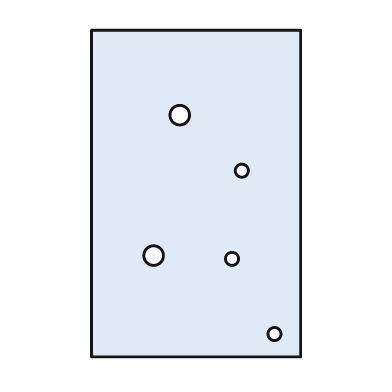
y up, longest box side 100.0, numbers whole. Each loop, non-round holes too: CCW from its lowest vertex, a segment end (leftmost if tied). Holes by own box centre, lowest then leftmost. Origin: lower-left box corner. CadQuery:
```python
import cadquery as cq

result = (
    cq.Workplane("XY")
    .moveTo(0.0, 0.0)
    .lineTo(64.0, 0.0)
    .lineTo(64.0, 100.0)
    .lineTo(0.0, 100.0)
    .close()
    .moveTo(56.0, 7.0)
    .circle(2.0)
    .moveTo(43.0, 30.0)
    .circle(2.0)
    .moveTo(19.0, 31.0)
    .circle(3.0)
    .moveTo(46.0, 57.0)
    .circle(2.0)
    .moveTo(27.0, 74.0)
    .circle(3.0)
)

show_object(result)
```